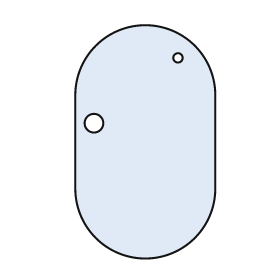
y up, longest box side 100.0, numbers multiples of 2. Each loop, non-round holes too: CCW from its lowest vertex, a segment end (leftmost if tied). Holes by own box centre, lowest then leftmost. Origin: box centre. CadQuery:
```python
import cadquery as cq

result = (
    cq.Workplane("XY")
    .moveTo(-30.0, -20.0)
    .threePointArc((0.0, -50.0), (30.0, -20.0))
    .lineTo(30.0, 20.0)
    .threePointArc((0.0, 50.0), (-30.0, 20.0))
    .close()
    .moveTo(-22.0, 8.0)
    .circle(4.0)
    .moveTo(14.0, 36.0)
    .circle(2.0)
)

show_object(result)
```